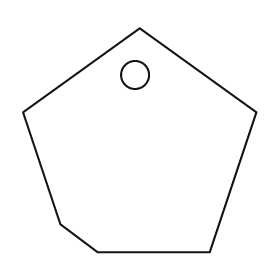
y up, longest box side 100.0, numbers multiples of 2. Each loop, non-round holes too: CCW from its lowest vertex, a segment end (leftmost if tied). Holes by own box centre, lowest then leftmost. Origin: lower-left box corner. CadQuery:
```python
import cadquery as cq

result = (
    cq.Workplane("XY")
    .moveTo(32.0, 0.0)
    .lineTo(80.0, 0.0)
    .lineTo(100.0, 60.0)
    .lineTo(50.0, 96.0)
    .lineTo(0.0, 60.0)
    .lineTo(16.0, 12.0)
    .close()
    .moveTo(48.0, 76.0)
    .circle(6.0)
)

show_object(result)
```